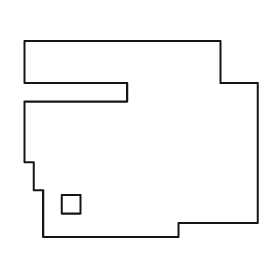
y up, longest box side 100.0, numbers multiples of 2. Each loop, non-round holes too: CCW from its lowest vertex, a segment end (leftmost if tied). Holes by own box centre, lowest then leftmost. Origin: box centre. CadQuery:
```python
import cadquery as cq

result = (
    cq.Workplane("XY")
    .moveTo(-42.0, -42.0)
    .lineTo(16.0, -42.0)
    .lineTo(16.0, -36.0)
    .lineTo(50.0, -36.0)
    .lineTo(50.0, 24.0)
    .lineTo(34.0, 24.0)
    .lineTo(34.0, 42.0)
    .lineTo(-50.0, 42.0)
    .lineTo(-50.0, 24.0)
    .lineTo(-6.0, 24.0)
    .lineTo(-6.0, 16.0)
    .lineTo(-50.0, 16.0)
    .lineTo(-50.0, -10.0)
    .lineTo(-46.0, -10.0)
    .lineTo(-46.0, -22.0)
    .lineTo(-42.0, -22.0)
    .close()
    .moveTo(-34.0, -32.0)
    .lineTo(-26.0, -32.0)
    .lineTo(-26.0, -24.0)
    .lineTo(-34.0, -24.0)
    .close()
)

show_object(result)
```